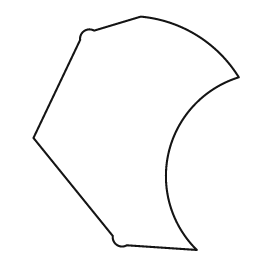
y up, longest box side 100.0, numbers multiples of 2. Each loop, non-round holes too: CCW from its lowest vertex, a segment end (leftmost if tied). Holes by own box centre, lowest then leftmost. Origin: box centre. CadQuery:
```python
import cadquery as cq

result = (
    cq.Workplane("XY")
    .moveTo(26.0, -50.0)
    .threePointArc((14.0, -8.0), (44.0, 24.0))
    .threePointArc((26.0, 42.0), (2.0, 50.0))
    .lineTo(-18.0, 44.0)
    .threePointArc((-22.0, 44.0), (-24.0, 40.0))
    .lineTo(-44.0, -2.0)
    .lineTo(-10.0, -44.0)
    .threePointArc((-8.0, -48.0), (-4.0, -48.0))
    .close()
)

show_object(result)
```